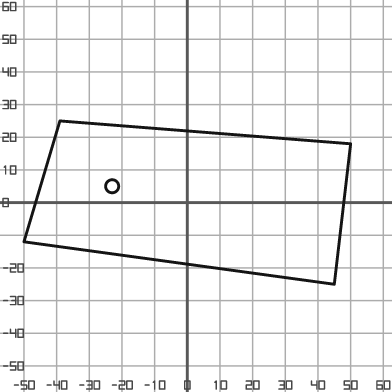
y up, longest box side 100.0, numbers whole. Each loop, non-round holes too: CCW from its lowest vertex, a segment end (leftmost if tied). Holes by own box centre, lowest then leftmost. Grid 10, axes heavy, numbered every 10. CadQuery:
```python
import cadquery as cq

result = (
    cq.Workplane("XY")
    .moveTo(45.0, -25.0)
    .lineTo(50.0, 18.0)
    .lineTo(-39.0, 25.0)
    .lineTo(-50.0, -12.0)
    .close()
    .moveTo(-23.0, 5.0)
    .circle(2.0)
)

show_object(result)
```